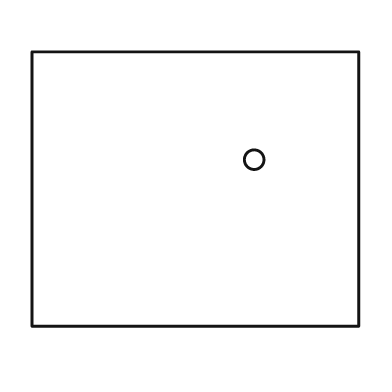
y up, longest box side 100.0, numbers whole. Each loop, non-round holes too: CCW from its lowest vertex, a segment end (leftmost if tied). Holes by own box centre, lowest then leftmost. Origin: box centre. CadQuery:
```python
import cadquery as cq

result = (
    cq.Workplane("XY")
    .moveTo(-50.0, -42.0)
    .lineTo(50.0, -42.0)
    .lineTo(50.0, 42.0)
    .lineTo(-50.0, 42.0)
    .close()
    .moveTo(18.0, 9.0)
    .circle(3.0)
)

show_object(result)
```